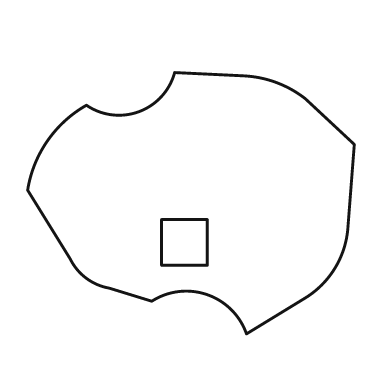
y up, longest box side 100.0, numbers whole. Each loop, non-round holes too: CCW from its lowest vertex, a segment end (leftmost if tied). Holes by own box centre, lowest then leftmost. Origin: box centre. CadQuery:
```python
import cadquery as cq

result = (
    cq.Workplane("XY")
    .moveTo(17.0, -40.0)
    .lineTo(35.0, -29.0)
    .threePointArc((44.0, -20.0), (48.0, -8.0))
    .lineTo(50.0, 18.0)
    .lineTo(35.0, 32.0)
    .threePointArc((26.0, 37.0), (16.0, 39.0))
    .lineTo(-5.0, 40.0)
    .threePointArc((-16.0, 28.0), (-32.0, 30.0))
    .threePointArc((-44.0, 19.0), (-50.0, 4.0))
    .lineTo(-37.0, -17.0)
    .threePointArc((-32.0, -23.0), (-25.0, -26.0))
    .lineTo(-12.0, -30.0)
    .threePointArc((5.0, -28.0), (17.0, -40.0))
    .close()
    .moveTo(-9.0, -19.0)
    .lineTo(5.0, -19.0)
    .lineTo(5.0, -5.0)
    .lineTo(-9.0, -5.0)
    .close()
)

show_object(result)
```